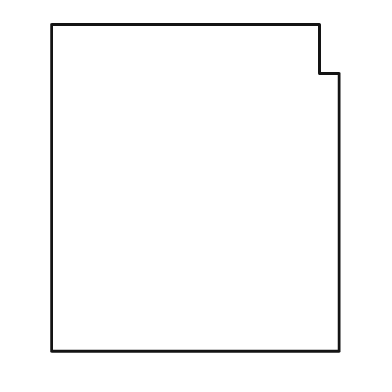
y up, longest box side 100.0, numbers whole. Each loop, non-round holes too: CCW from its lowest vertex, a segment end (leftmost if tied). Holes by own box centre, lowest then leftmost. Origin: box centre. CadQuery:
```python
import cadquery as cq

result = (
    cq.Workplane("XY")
    .moveTo(-44.0, -50.0)
    .lineTo(44.0, -50.0)
    .lineTo(44.0, 35.0)
    .lineTo(38.0, 35.0)
    .lineTo(38.0, 50.0)
    .lineTo(-44.0, 50.0)
    .close()
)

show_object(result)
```